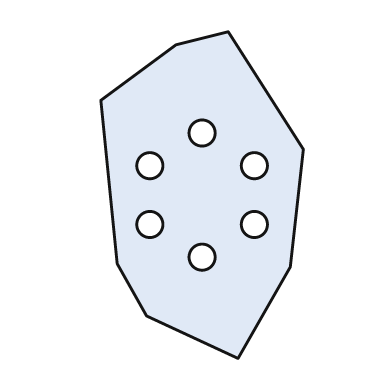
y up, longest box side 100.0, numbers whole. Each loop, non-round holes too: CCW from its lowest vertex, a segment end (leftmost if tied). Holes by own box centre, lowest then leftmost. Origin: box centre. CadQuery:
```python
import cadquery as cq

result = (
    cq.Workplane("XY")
    .moveTo(11.0, -50.0)
    .lineTo(27.0, -22.0)
    .lineTo(31.0, 14.0)
    .lineTo(8.0, 50.0)
    .lineTo(-8.0, 46.0)
    .lineTo(-31.0, 29.0)
    .lineTo(-26.0, -21.0)
    .lineTo(-17.0, -37.0)
    .close()
    .moveTo(0.0, -19.0)
    .circle(4.0)
    .moveTo(-16.0, -9.0)
    .circle(4.0)
    .moveTo(16.0, -9.0)
    .circle(4.0)
    .moveTo(-16.0, 9.0)
    .circle(4.0)
    .moveTo(16.0, 9.0)
    .circle(4.0)
    .moveTo(0.0, 19.0)
    .circle(4.0)
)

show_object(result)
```